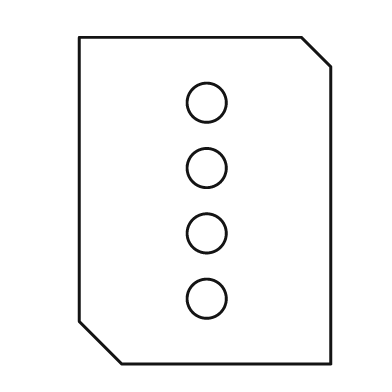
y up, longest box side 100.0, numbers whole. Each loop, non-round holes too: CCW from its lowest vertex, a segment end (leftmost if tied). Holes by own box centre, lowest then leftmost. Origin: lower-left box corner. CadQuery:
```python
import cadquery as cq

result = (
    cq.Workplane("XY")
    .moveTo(13.0, 0.0)
    .lineTo(77.0, 0.0)
    .lineTo(77.0, 91.0)
    .lineTo(68.0, 100.0)
    .lineTo(0.0, 100.0)
    .lineTo(0.0, 13.0)
    .close()
    .moveTo(39.0, 20.0)
    .circle(6.0)
    .moveTo(39.0, 40.0)
    .circle(6.0)
    .moveTo(39.0, 60.0)
    .circle(6.0)
    .moveTo(39.0, 80.0)
    .circle(6.0)
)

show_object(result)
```